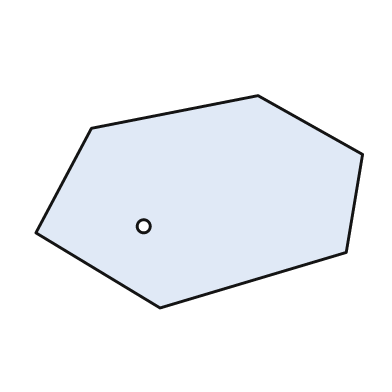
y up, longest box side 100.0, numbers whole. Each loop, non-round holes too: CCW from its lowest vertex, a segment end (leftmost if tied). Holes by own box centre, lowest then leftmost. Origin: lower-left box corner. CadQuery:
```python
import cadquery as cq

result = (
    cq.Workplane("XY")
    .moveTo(38.0, 0.0)
    .lineTo(95.0, 17.0)
    .lineTo(100.0, 47.0)
    .lineTo(68.0, 65.0)
    .lineTo(17.0, 55.0)
    .lineTo(0.0, 23.0)
    .close()
    .moveTo(33.0, 25.0)
    .circle(2.0)
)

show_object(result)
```